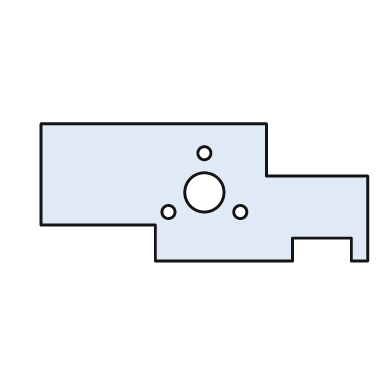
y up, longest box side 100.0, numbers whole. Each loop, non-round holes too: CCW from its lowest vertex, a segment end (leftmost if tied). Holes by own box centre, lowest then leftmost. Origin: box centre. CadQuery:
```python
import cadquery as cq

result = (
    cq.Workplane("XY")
    .moveTo(-15.0, -21.0)
    .lineTo(27.0, -21.0)
    .lineTo(27.0, -14.0)
    .lineTo(45.0, -14.0)
    .lineTo(45.0, -21.0)
    .lineTo(50.0, -21.0)
    .lineTo(50.0, 5.0)
    .lineTo(19.0, 5.0)
    .lineTo(19.0, 21.0)
    .lineTo(-50.0, 21.0)
    .lineTo(-50.0, -10.0)
    .lineTo(-15.0, -10.0)
    .close()
    .moveTo(-11.0, -6.0)
    .circle(2.0)
    .moveTo(11.0, -6.0)
    .circle(2.0)
    .moveTo(0.0, 0.0)
    .circle(6.0)
    .moveTo(0.0, 12.0)
    .circle(2.0)
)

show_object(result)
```